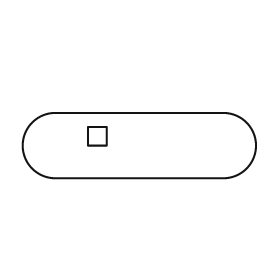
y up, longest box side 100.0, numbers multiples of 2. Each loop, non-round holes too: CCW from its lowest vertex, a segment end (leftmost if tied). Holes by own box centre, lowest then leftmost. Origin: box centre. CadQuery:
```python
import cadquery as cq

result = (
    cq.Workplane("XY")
    .moveTo(-36.0, -14.0)
    .lineTo(36.0, -14.0)
    .threePointArc((50.0, 0.0), (36.0, 14.0))
    .lineTo(-36.0, 14.0)
    .threePointArc((-50.0, 0.0), (-36.0, -14.0))
    .close()
    .moveTo(-22.0, 0.0)
    .lineTo(-14.0, 0.0)
    .lineTo(-14.0, 8.0)
    .lineTo(-22.0, 8.0)
    .close()
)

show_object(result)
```